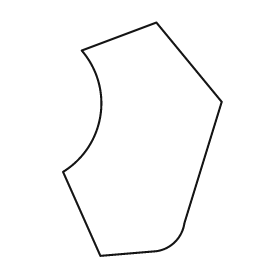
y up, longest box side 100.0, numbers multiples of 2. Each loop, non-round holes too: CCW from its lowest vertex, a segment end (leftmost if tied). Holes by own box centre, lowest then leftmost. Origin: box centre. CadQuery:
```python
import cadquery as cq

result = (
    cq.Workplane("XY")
    .moveTo(-18.0, -50.0)
    .lineTo(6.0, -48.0)
    .threePointArc((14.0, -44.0), (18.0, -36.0))
    .lineTo(34.0, 16.0)
    .lineTo(6.0, 50.0)
    .lineTo(-26.0, 38.0)
    .threePointArc((-18.0, 10.0), (-34.0, -14.0))
    .close()
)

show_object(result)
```